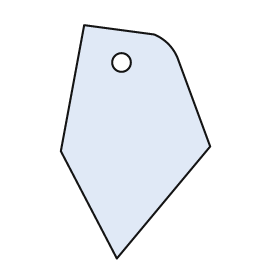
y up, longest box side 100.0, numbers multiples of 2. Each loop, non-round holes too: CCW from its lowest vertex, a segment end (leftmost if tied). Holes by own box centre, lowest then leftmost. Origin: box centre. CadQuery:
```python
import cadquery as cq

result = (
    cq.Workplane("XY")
    .moveTo(-8.0, -50.0)
    .lineTo(32.0, -2.0)
    .lineTo(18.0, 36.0)
    .threePointArc((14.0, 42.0), (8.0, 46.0))
    .lineTo(-22.0, 50.0)
    .lineTo(-32.0, -4.0)
    .close()
    .moveTo(-6.0, 34.0)
    .circle(4.0)
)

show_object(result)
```